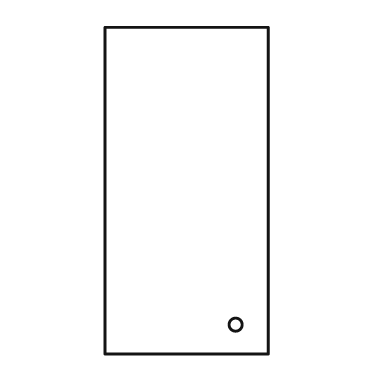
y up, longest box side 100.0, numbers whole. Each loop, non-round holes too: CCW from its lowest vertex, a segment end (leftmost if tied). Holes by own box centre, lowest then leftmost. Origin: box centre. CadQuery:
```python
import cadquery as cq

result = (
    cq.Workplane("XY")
    .moveTo(-25.0, -50.0)
    .lineTo(25.0, -50.0)
    .lineTo(25.0, 50.0)
    .lineTo(-25.0, 50.0)
    .close()
    .moveTo(15.0, -41.0)
    .circle(2.0)
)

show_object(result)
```